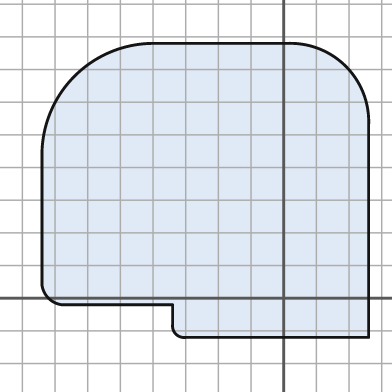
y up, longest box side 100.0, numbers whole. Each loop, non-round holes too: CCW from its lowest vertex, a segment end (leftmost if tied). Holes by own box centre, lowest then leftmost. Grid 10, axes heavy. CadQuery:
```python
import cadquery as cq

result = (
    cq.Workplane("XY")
    .moveTo(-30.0, -12.0)
    .lineTo(26.0, -12.0)
    .lineTo(26.0, 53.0)
    .threePointArc((19.0, 71.0), (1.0, 78.0))
    .lineTo(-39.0, 78.0)
    .threePointArc((-64.0, 68.0), (-74.0, 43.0))
    .lineTo(-74.0, 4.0)
    .threePointArc((-72.0, 0.0), (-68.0, -2.0))
    .lineTo(-34.0, -2.0)
    .lineTo(-34.0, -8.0)
    .threePointArc((-33.0, -11.0), (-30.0, -12.0))
    .close()
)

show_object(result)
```